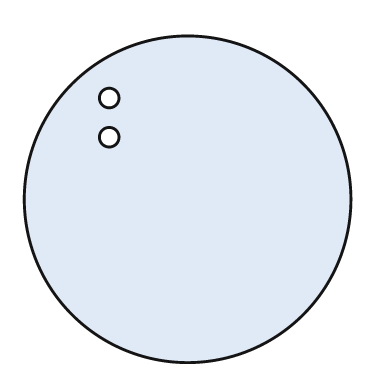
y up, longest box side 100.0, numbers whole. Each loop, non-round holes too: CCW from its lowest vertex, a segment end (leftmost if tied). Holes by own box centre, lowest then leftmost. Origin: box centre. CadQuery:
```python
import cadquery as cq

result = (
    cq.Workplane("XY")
    .moveTo(0.0, 0.0)
    .circle(50.0)
    .moveTo(-24.0, 19.0)
    .circle(3.0)
    .moveTo(-24.0, 31.0)
    .circle(3.0)
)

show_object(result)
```